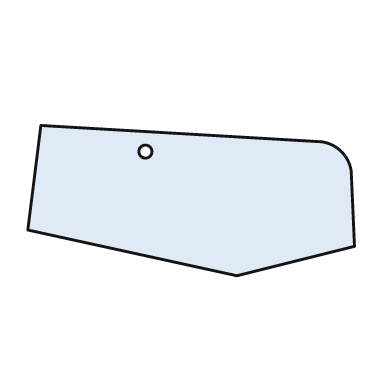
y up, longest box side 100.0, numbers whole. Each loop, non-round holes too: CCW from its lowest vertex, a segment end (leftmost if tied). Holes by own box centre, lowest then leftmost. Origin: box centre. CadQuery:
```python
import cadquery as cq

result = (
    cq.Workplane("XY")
    .moveTo(14.0, -23.0)
    .lineTo(50.0, -14.0)
    .lineTo(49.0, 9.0)
    .threePointArc((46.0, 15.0), (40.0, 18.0))
    .lineTo(-46.0, 23.0)
    .lineTo(-50.0, -9.0)
    .close()
    .moveTo(-14.0, 15.0)
    .circle(2.0)
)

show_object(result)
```